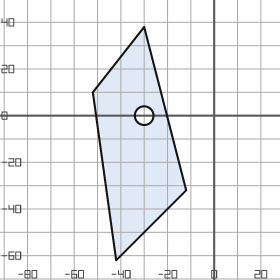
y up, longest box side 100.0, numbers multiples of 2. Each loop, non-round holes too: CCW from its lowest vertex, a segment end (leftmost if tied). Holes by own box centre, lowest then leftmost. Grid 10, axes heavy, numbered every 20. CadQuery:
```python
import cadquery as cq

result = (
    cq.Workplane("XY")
    .moveTo(-42.0, -62.0)
    .lineTo(-12.0, -32.0)
    .lineTo(-30.0, 38.0)
    .lineTo(-52.0, 10.0)
    .close()
    .moveTo(-30.0, 0.0)
    .circle(4.0)
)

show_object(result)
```